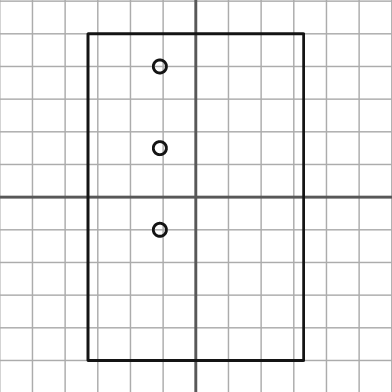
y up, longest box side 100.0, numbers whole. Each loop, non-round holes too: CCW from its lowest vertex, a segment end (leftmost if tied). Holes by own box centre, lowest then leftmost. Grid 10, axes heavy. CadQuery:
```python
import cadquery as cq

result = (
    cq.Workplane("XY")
    .moveTo(-33.0, -50.0)
    .lineTo(33.0, -50.0)
    .lineTo(33.0, 50.0)
    .lineTo(-33.0, 50.0)
    .close()
    .moveTo(-11.0, -10.0)
    .circle(2.0)
    .moveTo(-11.0, 15.0)
    .circle(2.0)
    .moveTo(-11.0, 40.0)
    .circle(2.0)
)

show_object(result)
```